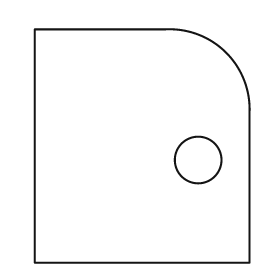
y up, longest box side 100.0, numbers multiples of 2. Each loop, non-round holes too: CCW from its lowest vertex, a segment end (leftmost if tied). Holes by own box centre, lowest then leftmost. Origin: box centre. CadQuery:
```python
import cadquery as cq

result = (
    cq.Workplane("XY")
    .moveTo(-46.0, -50.0)
    .lineTo(46.0, -50.0)
    .lineTo(46.0, 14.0)
    .threePointArc((36.0, 40.0), (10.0, 50.0))
    .lineTo(-46.0, 50.0)
    .close()
    .moveTo(24.0, -6.0)
    .circle(10.0)
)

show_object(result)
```